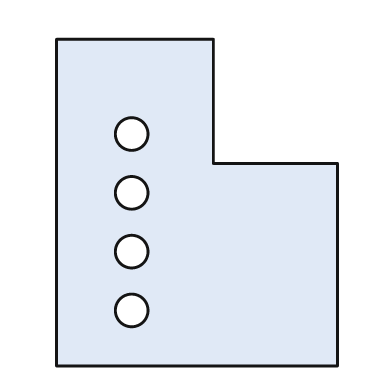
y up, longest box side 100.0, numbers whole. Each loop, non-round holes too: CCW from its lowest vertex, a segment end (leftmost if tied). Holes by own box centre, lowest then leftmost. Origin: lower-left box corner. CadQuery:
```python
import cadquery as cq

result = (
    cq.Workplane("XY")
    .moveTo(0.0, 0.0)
    .lineTo(86.0, 0.0)
    .lineTo(86.0, 62.0)
    .lineTo(48.0, 62.0)
    .lineTo(48.0, 100.0)
    .lineTo(0.0, 100.0)
    .close()
    .moveTo(23.0, 17.0)
    .circle(5.0)
    .moveTo(23.0, 35.0)
    .circle(5.0)
    .moveTo(23.0, 53.0)
    .circle(5.0)
    .moveTo(23.0, 71.0)
    .circle(5.0)
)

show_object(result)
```